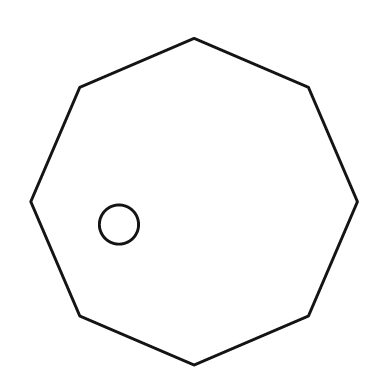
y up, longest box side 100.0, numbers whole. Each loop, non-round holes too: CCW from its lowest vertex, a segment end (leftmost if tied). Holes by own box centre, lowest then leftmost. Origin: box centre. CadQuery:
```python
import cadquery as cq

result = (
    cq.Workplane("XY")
    .moveTo(0.0, -50.0)
    .lineTo(35.0, -35.0)
    .lineTo(50.0, 0.0)
    .lineTo(35.0, 35.0)
    .lineTo(0.0, 50.0)
    .lineTo(-35.0, 35.0)
    .lineTo(-50.0, 0.0)
    .lineTo(-35.0, -35.0)
    .close()
    .moveTo(-23.0, -7.0)
    .circle(6.0)
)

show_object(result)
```